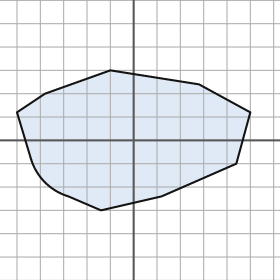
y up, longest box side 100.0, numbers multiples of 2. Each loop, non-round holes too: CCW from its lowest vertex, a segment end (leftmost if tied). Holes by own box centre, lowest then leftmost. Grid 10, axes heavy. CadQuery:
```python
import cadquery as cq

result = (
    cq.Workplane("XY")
    .moveTo(-14.0, -30.0)
    .lineTo(12.0, -24.0)
    .lineTo(44.0, -10.0)
    .lineTo(50.0, 12.0)
    .lineTo(28.0, 24.0)
    .lineTo(-10.0, 30.0)
    .lineTo(-38.0, 20.0)
    .lineTo(-50.0, 12.0)
    .lineTo(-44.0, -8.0)
    .threePointArc((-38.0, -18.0), (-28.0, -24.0))
    .close()
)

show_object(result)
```